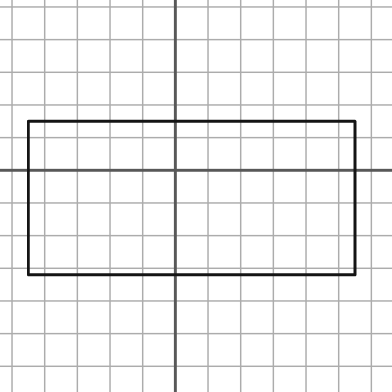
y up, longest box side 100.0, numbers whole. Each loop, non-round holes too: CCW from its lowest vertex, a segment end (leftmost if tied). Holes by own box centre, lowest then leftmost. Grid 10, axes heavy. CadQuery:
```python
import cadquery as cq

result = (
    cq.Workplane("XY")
    .moveTo(-45.0, -32.0)
    .lineTo(55.0, -32.0)
    .lineTo(55.0, 15.0)
    .lineTo(-45.0, 15.0)
    .close()
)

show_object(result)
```